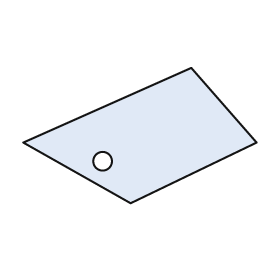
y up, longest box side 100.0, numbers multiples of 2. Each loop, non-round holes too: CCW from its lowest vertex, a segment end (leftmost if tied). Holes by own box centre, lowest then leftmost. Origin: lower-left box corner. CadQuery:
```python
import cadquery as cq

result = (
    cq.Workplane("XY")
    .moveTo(46.0, 0.0)
    .lineTo(100.0, 26.0)
    .lineTo(72.0, 58.0)
    .lineTo(0.0, 26.0)
    .close()
    .moveTo(34.0, 18.0)
    .circle(4.0)
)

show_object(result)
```